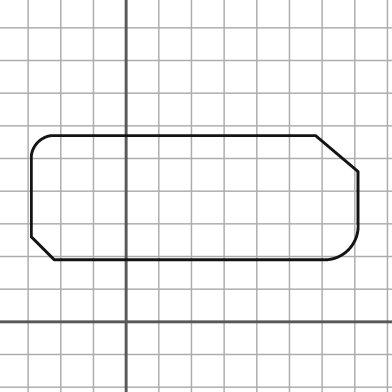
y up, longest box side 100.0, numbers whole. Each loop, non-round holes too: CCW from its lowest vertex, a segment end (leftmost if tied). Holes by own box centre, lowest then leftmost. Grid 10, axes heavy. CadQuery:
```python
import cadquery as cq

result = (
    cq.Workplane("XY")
    .moveTo(-22.0, 19.0)
    .lineTo(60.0, 19.0)
    .threePointArc((68.0, 22.0), (71.0, 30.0))
    .lineTo(71.0, 46.0)
    .lineTo(58.0, 57.0)
    .lineTo(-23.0, 57.0)
    .threePointArc((-27.0, 55.0), (-29.0, 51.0))
    .lineTo(-29.0, 26.0)
    .close()
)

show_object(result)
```